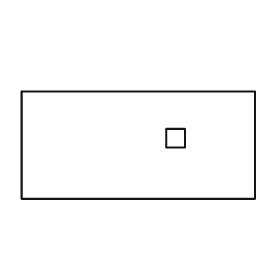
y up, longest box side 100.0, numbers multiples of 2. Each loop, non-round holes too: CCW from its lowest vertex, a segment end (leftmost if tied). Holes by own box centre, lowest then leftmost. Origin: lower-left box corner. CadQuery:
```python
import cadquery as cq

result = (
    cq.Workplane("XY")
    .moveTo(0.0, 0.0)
    .lineTo(100.0, 0.0)
    .lineTo(100.0, 46.0)
    .lineTo(0.0, 46.0)
    .close()
    .moveTo(62.0, 22.0)
    .lineTo(70.0, 22.0)
    .lineTo(70.0, 30.0)
    .lineTo(62.0, 30.0)
    .close()
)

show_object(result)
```